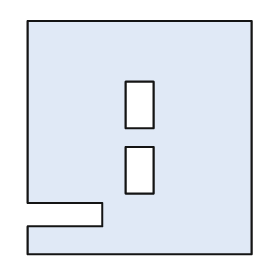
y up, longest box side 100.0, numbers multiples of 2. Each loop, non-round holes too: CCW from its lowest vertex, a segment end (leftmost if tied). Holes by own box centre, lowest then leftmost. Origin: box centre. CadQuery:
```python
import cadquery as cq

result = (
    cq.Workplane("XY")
    .moveTo(-48.0, -50.0)
    .lineTo(48.0, -50.0)
    .lineTo(48.0, 50.0)
    .lineTo(-48.0, 50.0)
    .lineTo(-48.0, -28.0)
    .lineTo(-16.0, -28.0)
    .lineTo(-16.0, -38.0)
    .lineTo(-48.0, -38.0)
    .close()
    .moveTo(-6.0, -24.0)
    .lineTo(6.0, -24.0)
    .lineTo(6.0, -4.0)
    .lineTo(-6.0, -4.0)
    .close()
    .moveTo(-6.0, 4.0)
    .lineTo(6.0, 4.0)
    .lineTo(6.0, 24.0)
    .lineTo(-6.0, 24.0)
    .close()
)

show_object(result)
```